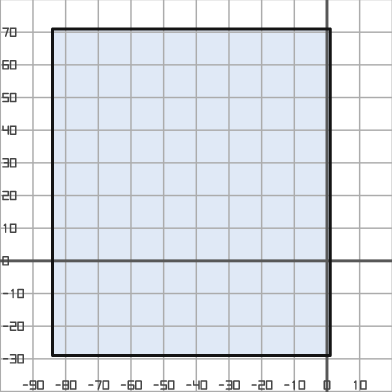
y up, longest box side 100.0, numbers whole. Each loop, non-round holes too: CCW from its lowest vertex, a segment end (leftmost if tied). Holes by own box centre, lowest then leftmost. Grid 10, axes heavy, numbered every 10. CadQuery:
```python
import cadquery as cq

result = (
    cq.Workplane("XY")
    .moveTo(-84.0, -29.0)
    .lineTo(1.0, -29.0)
    .lineTo(1.0, 71.0)
    .lineTo(-84.0, 71.0)
    .close()
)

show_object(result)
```